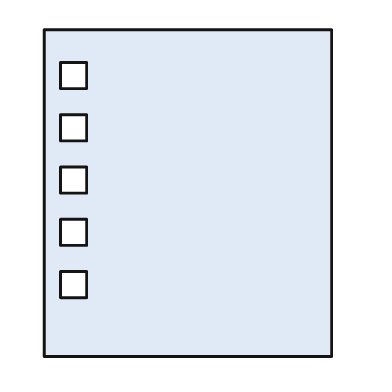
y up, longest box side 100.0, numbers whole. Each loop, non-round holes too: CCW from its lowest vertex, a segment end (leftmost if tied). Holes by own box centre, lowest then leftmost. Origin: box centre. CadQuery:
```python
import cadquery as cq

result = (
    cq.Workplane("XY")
    .moveTo(-44.0, -50.0)
    .lineTo(44.0, -50.0)
    .lineTo(44.0, 50.0)
    .lineTo(-44.0, 50.0)
    .close()
    .moveTo(-39.0, -32.0)
    .lineTo(-31.0, -32.0)
    .lineTo(-31.0, -24.0)
    .lineTo(-39.0, -24.0)
    .close()
    .moveTo(-39.0, -16.0)
    .lineTo(-31.0, -16.0)
    .lineTo(-31.0, -8.0)
    .lineTo(-39.0, -8.0)
    .close()
    .moveTo(-39.0, 0.0)
    .lineTo(-31.0, 0.0)
    .lineTo(-31.0, 8.0)
    .lineTo(-39.0, 8.0)
    .close()
    .moveTo(-39.0, 16.0)
    .lineTo(-31.0, 16.0)
    .lineTo(-31.0, 24.0)
    .lineTo(-39.0, 24.0)
    .close()
    .moveTo(-39.0, 32.0)
    .lineTo(-31.0, 32.0)
    .lineTo(-31.0, 40.0)
    .lineTo(-39.0, 40.0)
    .close()
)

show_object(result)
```